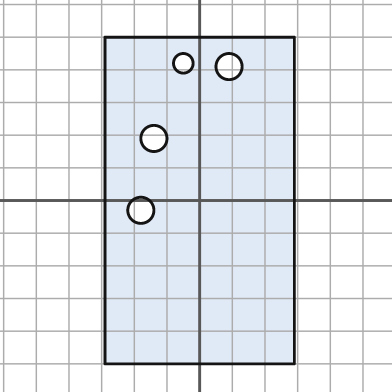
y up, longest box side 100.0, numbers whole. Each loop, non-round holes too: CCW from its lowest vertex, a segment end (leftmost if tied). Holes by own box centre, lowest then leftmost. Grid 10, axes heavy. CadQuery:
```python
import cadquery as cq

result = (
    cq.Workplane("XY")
    .moveTo(-29.0, -50.0)
    .lineTo(29.0, -50.0)
    .lineTo(29.0, 50.0)
    .lineTo(-29.0, 50.0)
    .close()
    .moveTo(-18.0, -3.0)
    .circle(4.0)
    .moveTo(-14.0, 19.0)
    .circle(4.0)
    .moveTo(9.0, 41.0)
    .circle(4.0)
    .moveTo(-5.0, 42.0)
    .circle(3.0)
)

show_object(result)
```